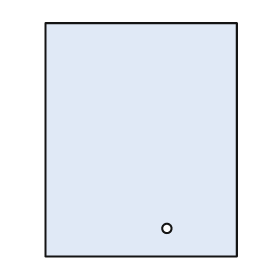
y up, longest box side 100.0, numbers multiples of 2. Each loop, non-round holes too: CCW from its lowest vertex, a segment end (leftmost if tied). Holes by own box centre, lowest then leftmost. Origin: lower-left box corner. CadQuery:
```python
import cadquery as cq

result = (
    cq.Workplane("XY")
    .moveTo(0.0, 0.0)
    .lineTo(82.0, 0.0)
    .lineTo(82.0, 100.0)
    .lineTo(0.0, 100.0)
    .close()
    .moveTo(52.0, 12.0)
    .circle(2.0)
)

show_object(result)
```